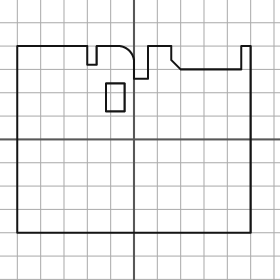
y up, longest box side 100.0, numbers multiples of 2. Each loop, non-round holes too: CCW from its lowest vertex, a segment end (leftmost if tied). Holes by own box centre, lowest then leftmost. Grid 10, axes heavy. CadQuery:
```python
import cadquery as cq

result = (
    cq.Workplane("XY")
    .moveTo(-50.0, -40.0)
    .lineTo(50.0, -40.0)
    .lineTo(50.0, 40.0)
    .lineTo(46.0, 40.0)
    .lineTo(46.0, 30.0)
    .lineTo(20.0, 30.0)
    .lineTo(16.0, 34.0)
    .lineTo(16.0, 40.0)
    .lineTo(6.0, 40.0)
    .lineTo(6.0, 26.0)
    .lineTo(0.0, 26.0)
    .lineTo(0.0, 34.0)
    .threePointArc((-2.0, 38.0), (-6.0, 40.0))
    .lineTo(-16.0, 40.0)
    .lineTo(-16.0, 32.0)
    .lineTo(-20.0, 32.0)
    .lineTo(-20.0, 40.0)
    .lineTo(-50.0, 40.0)
    .close()
    .moveTo(-12.0, 12.0)
    .lineTo(-4.0, 12.0)
    .lineTo(-4.0, 24.0)
    .lineTo(-12.0, 24.0)
    .close()
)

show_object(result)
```